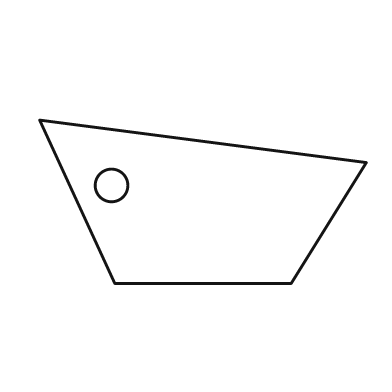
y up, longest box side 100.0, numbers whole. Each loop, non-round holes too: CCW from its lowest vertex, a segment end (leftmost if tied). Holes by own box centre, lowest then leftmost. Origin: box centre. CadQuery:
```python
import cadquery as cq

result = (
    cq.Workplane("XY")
    .moveTo(-27.0, -25.0)
    .lineTo(27.0, -25.0)
    .lineTo(50.0, 12.0)
    .lineTo(-50.0, 25.0)
    .close()
    .moveTo(-28.0, 5.0)
    .circle(5.0)
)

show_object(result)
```